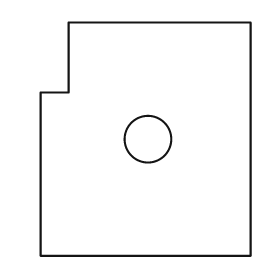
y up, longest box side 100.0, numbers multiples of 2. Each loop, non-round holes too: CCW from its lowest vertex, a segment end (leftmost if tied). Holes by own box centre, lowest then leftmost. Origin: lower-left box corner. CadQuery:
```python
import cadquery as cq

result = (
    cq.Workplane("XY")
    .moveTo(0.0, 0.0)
    .lineTo(90.0, 0.0)
    .lineTo(90.0, 100.0)
    .lineTo(12.0, 100.0)
    .lineTo(12.0, 70.0)
    .lineTo(0.0, 70.0)
    .close()
    .moveTo(46.0, 50.0)
    .circle(10.0)
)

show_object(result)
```